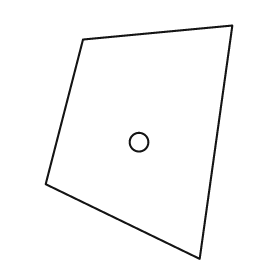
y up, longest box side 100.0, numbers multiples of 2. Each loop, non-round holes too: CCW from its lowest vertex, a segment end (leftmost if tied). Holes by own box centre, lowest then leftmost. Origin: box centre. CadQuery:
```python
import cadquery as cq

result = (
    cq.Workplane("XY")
    .moveTo(26.0, -50.0)
    .lineTo(40.0, 50.0)
    .lineTo(-24.0, 44.0)
    .lineTo(-40.0, -18.0)
    .close()
    .moveTo(0.0, 0.0)
    .circle(4.0)
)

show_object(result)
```